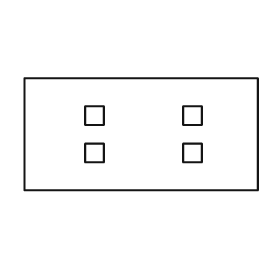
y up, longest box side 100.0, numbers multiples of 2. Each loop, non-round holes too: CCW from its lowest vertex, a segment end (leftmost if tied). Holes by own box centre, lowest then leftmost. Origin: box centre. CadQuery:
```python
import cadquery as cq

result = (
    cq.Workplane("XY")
    .moveTo(-50.0, -24.0)
    .lineTo(50.0, -24.0)
    .lineTo(50.0, 24.0)
    .lineTo(-50.0, 24.0)
    .close()
    .moveTo(-24.0, -12.0)
    .lineTo(-16.0, -12.0)
    .lineTo(-16.0, -4.0)
    .lineTo(-24.0, -4.0)
    .close()
    .moveTo(18.0, -12.0)
    .lineTo(26.0, -12.0)
    .lineTo(26.0, -4.0)
    .lineTo(18.0, -4.0)
    .close()
    .moveTo(-24.0, 4.0)
    .lineTo(-16.0, 4.0)
    .lineTo(-16.0, 12.0)
    .lineTo(-24.0, 12.0)
    .close()
    .moveTo(18.0, 4.0)
    .lineTo(26.0, 4.0)
    .lineTo(26.0, 12.0)
    .lineTo(18.0, 12.0)
    .close()
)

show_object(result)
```